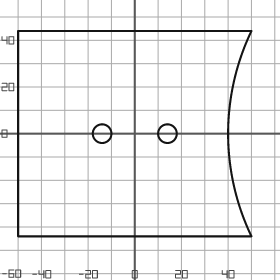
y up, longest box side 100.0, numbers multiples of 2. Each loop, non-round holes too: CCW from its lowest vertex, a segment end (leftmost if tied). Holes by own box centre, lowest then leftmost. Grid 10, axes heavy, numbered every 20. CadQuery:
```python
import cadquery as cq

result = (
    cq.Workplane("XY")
    .moveTo(-50.0, -44.0)
    .lineTo(50.0, -44.0)
    .threePointArc((40.0, 0.0), (50.0, 44.0))
    .lineTo(-50.0, 44.0)
    .close()
    .moveTo(-14.0, 0.0)
    .circle(4.0)
    .moveTo(14.0, 0.0)
    .circle(4.0)
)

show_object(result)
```